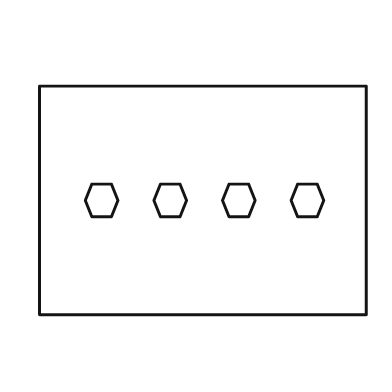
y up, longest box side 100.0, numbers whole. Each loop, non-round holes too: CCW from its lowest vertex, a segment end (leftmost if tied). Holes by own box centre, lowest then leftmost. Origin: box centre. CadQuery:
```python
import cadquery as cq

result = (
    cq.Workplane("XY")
    .moveTo(-50.0, -35.0)
    .lineTo(50.0, -35.0)
    .lineTo(50.0, 35.0)
    .lineTo(-50.0, 35.0)
    .close()
    .moveTo(-34.0, -5.0)
    .lineTo(-28.0, -5.0)
    .lineTo(-26.0, 0.0)
    .lineTo(-28.0, 5.0)
    .lineTo(-34.0, 5.0)
    .lineTo(-36.0, 0.0)
    .close()
    .moveTo(-13.0, -5.0)
    .lineTo(-7.0, -5.0)
    .lineTo(-5.0, 0.0)
    .lineTo(-7.0, 5.0)
    .lineTo(-13.0, 5.0)
    .lineTo(-15.0, 0.0)
    .close()
    .moveTo(8.0, -5.0)
    .lineTo(14.0, -5.0)
    .lineTo(16.0, 0.0)
    .lineTo(14.0, 5.0)
    .lineTo(8.0, 5.0)
    .lineTo(6.0, 0.0)
    .close()
    .moveTo(29.0, -5.0)
    .lineTo(35.0, -5.0)
    .lineTo(37.0, 0.0)
    .lineTo(35.0, 5.0)
    .lineTo(29.0, 5.0)
    .lineTo(27.0, 0.0)
    .close()
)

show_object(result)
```